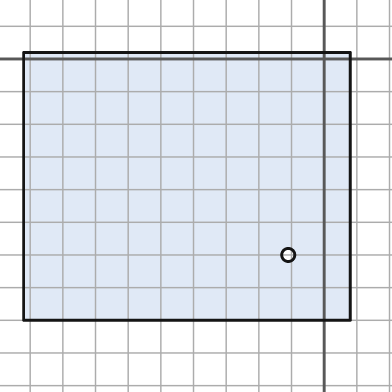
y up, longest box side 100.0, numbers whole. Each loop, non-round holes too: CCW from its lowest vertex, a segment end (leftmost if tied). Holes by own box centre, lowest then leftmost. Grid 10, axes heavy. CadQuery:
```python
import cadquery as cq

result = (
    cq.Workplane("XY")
    .moveTo(-92.0, -80.0)
    .lineTo(8.0, -80.0)
    .lineTo(8.0, 2.0)
    .lineTo(-92.0, 2.0)
    .close()
    .moveTo(-11.0, -60.0)
    .circle(2.0)
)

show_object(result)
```